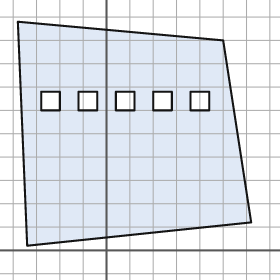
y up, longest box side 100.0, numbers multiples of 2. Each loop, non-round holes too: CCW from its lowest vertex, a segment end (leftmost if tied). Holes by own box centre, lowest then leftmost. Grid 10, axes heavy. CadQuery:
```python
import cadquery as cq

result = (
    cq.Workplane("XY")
    .moveTo(-34.0, 2.0)
    .lineTo(62.0, 12.0)
    .lineTo(50.0, 90.0)
    .lineTo(-38.0, 98.0)
    .close()
    .moveTo(-28.0, 60.0)
    .lineTo(-20.0, 60.0)
    .lineTo(-20.0, 68.0)
    .lineTo(-28.0, 68.0)
    .close()
    .moveTo(-12.0, 60.0)
    .lineTo(-4.0, 60.0)
    .lineTo(-4.0, 68.0)
    .lineTo(-12.0, 68.0)
    .close()
    .moveTo(4.0, 60.0)
    .lineTo(12.0, 60.0)
    .lineTo(12.0, 68.0)
    .lineTo(4.0, 68.0)
    .close()
    .moveTo(20.0, 60.0)
    .lineTo(28.0, 60.0)
    .lineTo(28.0, 68.0)
    .lineTo(20.0, 68.0)
    .close()
    .moveTo(36.0, 60.0)
    .lineTo(44.0, 60.0)
    .lineTo(44.0, 68.0)
    .lineTo(36.0, 68.0)
    .close()
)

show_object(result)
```